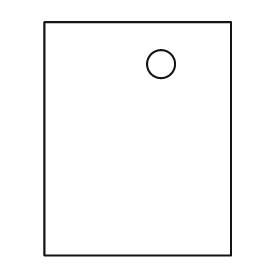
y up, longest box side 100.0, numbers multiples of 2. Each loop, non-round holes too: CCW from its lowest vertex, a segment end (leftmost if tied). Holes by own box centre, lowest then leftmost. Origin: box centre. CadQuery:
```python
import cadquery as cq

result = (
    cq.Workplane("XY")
    .moveTo(-40.0, -50.0)
    .lineTo(40.0, -50.0)
    .lineTo(40.0, 50.0)
    .lineTo(-40.0, 50.0)
    .close()
    .moveTo(10.0, 32.0)
    .circle(6.0)
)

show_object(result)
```